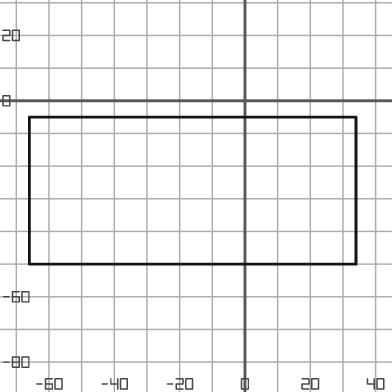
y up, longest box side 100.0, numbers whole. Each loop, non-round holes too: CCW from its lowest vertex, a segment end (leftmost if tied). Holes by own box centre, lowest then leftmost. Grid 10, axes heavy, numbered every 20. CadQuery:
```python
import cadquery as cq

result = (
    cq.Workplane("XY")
    .moveTo(-66.0, -50.0)
    .lineTo(34.0, -50.0)
    .lineTo(34.0, -5.0)
    .lineTo(-66.0, -5.0)
    .close()
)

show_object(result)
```